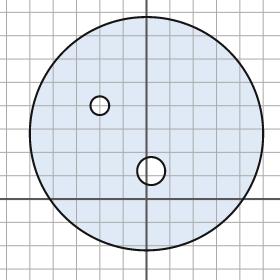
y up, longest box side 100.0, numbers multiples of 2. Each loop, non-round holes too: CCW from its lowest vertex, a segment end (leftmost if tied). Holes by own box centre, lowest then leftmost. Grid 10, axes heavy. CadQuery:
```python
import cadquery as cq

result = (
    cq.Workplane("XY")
    .moveTo(0.0, 28.0)
    .circle(50.0)
    .moveTo(2.0, 12.0)
    .circle(6.0)
    .moveTo(-20.0, 40.0)
    .circle(4.0)
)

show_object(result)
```